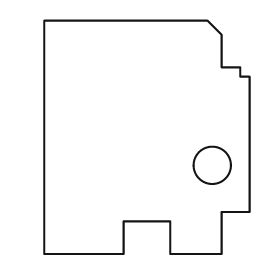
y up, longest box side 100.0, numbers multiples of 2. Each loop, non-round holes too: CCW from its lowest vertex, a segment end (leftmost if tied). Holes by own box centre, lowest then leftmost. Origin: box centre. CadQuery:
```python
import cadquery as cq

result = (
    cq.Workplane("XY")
    .moveTo(-44.0, -50.0)
    .lineTo(-10.0, -50.0)
    .lineTo(-10.0, -36.0)
    .lineTo(10.0, -36.0)
    .lineTo(10.0, -50.0)
    .lineTo(32.0, -50.0)
    .lineTo(32.0, -32.0)
    .lineTo(44.0, -32.0)
    .lineTo(44.0, 26.0)
    .lineTo(40.0, 26.0)
    .lineTo(40.0, 30.0)
    .lineTo(32.0, 30.0)
    .lineTo(32.0, 44.0)
    .lineTo(26.0, 50.0)
    .lineTo(-44.0, 50.0)
    .close()
    .moveTo(28.0, -12.0)
    .circle(8.0)
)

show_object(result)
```